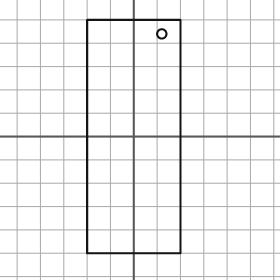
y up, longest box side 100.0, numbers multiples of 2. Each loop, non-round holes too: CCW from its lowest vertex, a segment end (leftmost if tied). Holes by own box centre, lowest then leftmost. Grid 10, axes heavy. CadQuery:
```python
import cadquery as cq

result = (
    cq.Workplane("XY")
    .moveTo(-20.0, -50.0)
    .lineTo(20.0, -50.0)
    .lineTo(20.0, 50.0)
    .lineTo(-20.0, 50.0)
    .close()
    .moveTo(12.0, 44.0)
    .circle(2.0)
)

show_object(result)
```